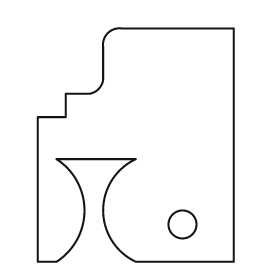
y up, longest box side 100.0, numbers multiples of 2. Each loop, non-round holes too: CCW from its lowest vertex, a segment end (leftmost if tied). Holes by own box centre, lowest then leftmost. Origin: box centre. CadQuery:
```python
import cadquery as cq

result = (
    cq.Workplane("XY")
    .moveTo(-42.0, -50.0)
    .lineTo(-34.0, -50.0)
    .threePointArc((-22.0, -28.0), (-34.0, -6.0))
    .lineTo(0.0, -6.0)
    .threePointArc((-14.0, -28.0), (0.0, -50.0))
    .lineTo(42.0, -50.0)
    .lineTo(42.0, 50.0)
    .lineTo(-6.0, 50.0)
    .threePointArc((-12.0, 48.0), (-14.0, 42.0))
    .lineTo(-14.0, 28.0)
    .threePointArc((-16.0, 24.0), (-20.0, 22.0))
    .lineTo(-30.0, 22.0)
    .lineTo(-30.0, 12.0)
    .lineTo(-42.0, 12.0)
    .close()
    .moveTo(20.0, -34.0)
    .circle(6.0)
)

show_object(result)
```